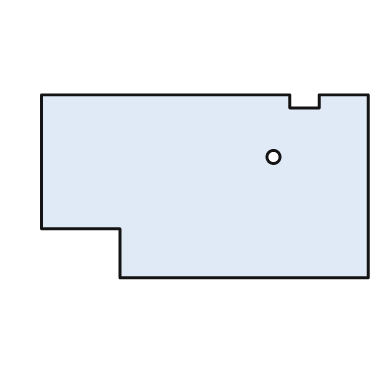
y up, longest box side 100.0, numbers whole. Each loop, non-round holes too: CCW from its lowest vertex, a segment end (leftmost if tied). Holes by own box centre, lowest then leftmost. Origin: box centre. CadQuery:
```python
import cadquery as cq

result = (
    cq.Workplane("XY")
    .moveTo(-26.0, -28.0)
    .lineTo(50.0, -28.0)
    .lineTo(50.0, 28.0)
    .lineTo(35.0, 28.0)
    .lineTo(35.0, 24.0)
    .lineTo(26.0, 24.0)
    .lineTo(26.0, 28.0)
    .lineTo(-50.0, 28.0)
    .lineTo(-50.0, -13.0)
    .lineTo(-26.0, -13.0)
    .close()
    .moveTo(21.0, 9.0)
    .circle(2.0)
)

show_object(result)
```